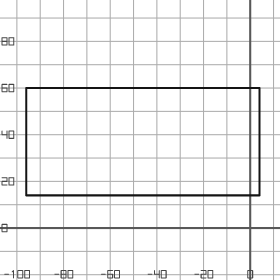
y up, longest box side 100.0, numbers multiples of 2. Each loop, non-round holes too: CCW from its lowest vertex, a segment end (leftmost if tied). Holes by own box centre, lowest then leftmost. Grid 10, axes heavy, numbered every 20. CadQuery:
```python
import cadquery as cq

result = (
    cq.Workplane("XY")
    .moveTo(-96.0, 14.0)
    .lineTo(4.0, 14.0)
    .lineTo(4.0, 60.0)
    .lineTo(-96.0, 60.0)
    .close()
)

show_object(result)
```